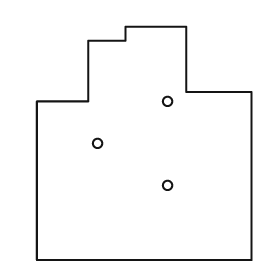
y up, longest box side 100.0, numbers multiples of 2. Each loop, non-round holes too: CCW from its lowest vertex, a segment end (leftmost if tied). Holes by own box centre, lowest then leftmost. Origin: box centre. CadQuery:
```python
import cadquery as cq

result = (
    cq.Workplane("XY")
    .moveTo(-46.0, -50.0)
    .lineTo(46.0, -50.0)
    .lineTo(46.0, 22.0)
    .lineTo(18.0, 22.0)
    .lineTo(18.0, 50.0)
    .lineTo(-8.0, 50.0)
    .lineTo(-8.0, 44.0)
    .lineTo(-24.0, 44.0)
    .lineTo(-24.0, 18.0)
    .lineTo(-46.0, 18.0)
    .close()
    .moveTo(10.0, -18.0)
    .circle(2.0)
    .moveTo(-20.0, 0.0)
    .circle(2.0)
    .moveTo(10.0, 18.0)
    .circle(2.0)
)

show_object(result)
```